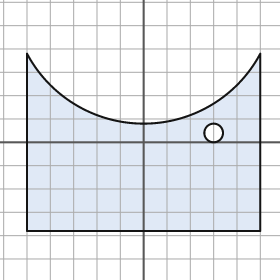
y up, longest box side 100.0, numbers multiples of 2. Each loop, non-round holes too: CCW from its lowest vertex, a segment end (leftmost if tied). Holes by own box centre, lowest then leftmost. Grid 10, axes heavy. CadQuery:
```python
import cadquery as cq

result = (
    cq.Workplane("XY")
    .moveTo(-50.0, -38.0)
    .lineTo(50.0, -38.0)
    .lineTo(50.0, 38.0)
    .threePointArc((0.0, 8.0), (-50.0, 38.0))
    .close()
    .moveTo(30.0, 4.0)
    .circle(4.0)
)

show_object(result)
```